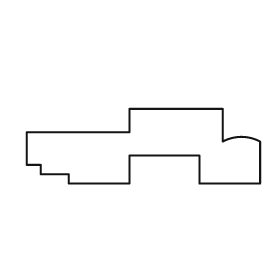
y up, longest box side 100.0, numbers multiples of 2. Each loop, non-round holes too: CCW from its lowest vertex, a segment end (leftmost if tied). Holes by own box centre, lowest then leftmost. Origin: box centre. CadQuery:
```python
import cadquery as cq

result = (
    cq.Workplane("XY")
    .moveTo(-32.0, -16.0)
    .lineTo(-6.0, -16.0)
    .lineTo(-6.0, -4.0)
    .lineTo(24.0, -4.0)
    .lineTo(24.0, -16.0)
    .lineTo(50.0, -16.0)
    .lineTo(50.0, 2.0)
    .threePointArc((42.0, 4.0), (34.0, 2.0))
    .lineTo(34.0, 16.0)
    .lineTo(-6.0, 16.0)
    .lineTo(-6.0, 6.0)
    .lineTo(-50.0, 6.0)
    .lineTo(-50.0, -8.0)
    .lineTo(-44.0, -8.0)
    .lineTo(-44.0, -12.0)
    .lineTo(-32.0, -12.0)
    .close()
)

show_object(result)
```